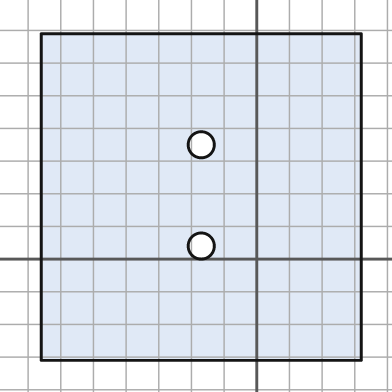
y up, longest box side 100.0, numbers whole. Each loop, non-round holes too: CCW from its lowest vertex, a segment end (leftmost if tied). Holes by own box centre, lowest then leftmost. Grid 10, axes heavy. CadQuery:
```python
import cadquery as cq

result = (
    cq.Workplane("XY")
    .moveTo(-66.0, -31.0)
    .lineTo(32.0, -31.0)
    .lineTo(32.0, 69.0)
    .lineTo(-66.0, 69.0)
    .close()
    .moveTo(-17.0, 4.0)
    .circle(4.0)
    .moveTo(-17.0, 35.0)
    .circle(4.0)
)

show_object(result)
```